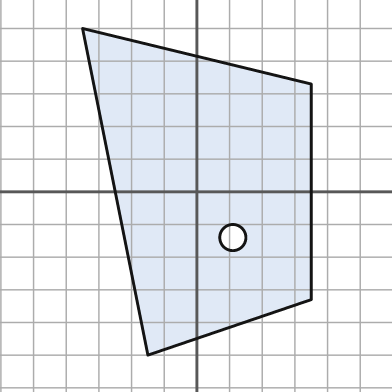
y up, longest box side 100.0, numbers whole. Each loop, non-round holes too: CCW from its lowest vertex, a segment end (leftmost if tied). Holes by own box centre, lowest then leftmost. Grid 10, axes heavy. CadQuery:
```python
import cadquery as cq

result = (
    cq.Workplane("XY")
    .moveTo(-15.0, -50.0)
    .lineTo(35.0, -33.0)
    .lineTo(35.0, 33.0)
    .lineTo(-35.0, 50.0)
    .close()
    .moveTo(11.0, -14.0)
    .circle(4.0)
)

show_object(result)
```